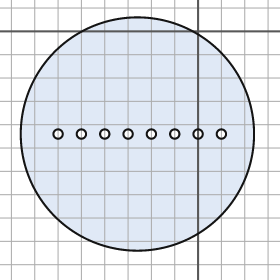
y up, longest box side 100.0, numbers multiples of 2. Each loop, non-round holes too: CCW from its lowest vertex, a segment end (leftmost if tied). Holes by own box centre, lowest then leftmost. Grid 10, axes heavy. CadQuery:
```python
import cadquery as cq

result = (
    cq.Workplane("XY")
    .moveTo(-26.0, -44.0)
    .circle(50.0)
    .moveTo(-60.0, -44.0)
    .circle(2.0)
    .moveTo(-50.0, -44.0)
    .circle(2.0)
    .moveTo(-40.0, -44.0)
    .circle(2.0)
    .moveTo(-30.0, -44.0)
    .circle(2.0)
    .moveTo(-20.0, -44.0)
    .circle(2.0)
    .moveTo(-10.0, -44.0)
    .circle(2.0)
    .moveTo(0.0, -44.0)
    .circle(2.0)
    .moveTo(10.0, -44.0)
    .circle(2.0)
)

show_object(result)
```